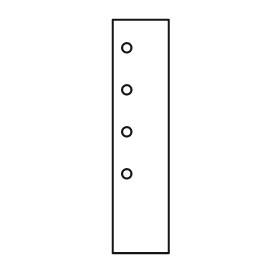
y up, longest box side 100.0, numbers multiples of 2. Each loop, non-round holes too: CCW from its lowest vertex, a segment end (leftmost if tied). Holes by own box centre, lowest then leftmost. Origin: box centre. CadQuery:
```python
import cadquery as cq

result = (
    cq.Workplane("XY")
    .moveTo(-12.0, -50.0)
    .lineTo(12.0, -50.0)
    .lineTo(12.0, 50.0)
    .lineTo(-12.0, 50.0)
    .close()
    .moveTo(-6.0, -16.0)
    .circle(2.0)
    .moveTo(-6.0, 2.0)
    .circle(2.0)
    .moveTo(-6.0, 20.0)
    .circle(2.0)
    .moveTo(-6.0, 38.0)
    .circle(2.0)
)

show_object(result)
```